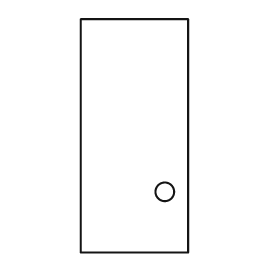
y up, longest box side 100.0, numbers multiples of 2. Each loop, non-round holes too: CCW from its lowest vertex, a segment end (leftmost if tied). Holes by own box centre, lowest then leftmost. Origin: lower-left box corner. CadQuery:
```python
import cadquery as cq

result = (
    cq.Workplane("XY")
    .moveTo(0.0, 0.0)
    .lineTo(46.0, 0.0)
    .lineTo(46.0, 100.0)
    .lineTo(0.0, 100.0)
    .close()
    .moveTo(36.0, 26.0)
    .circle(4.0)
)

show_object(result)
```